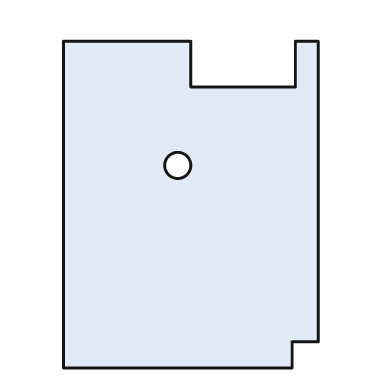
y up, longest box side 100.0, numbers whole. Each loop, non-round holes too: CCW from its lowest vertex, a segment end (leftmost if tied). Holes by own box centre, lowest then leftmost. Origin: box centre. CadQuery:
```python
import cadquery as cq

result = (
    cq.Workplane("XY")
    .moveTo(-39.0, -50.0)
    .lineTo(31.0, -50.0)
    .lineTo(31.0, -42.0)
    .lineTo(39.0, -42.0)
    .lineTo(39.0, 50.0)
    .lineTo(32.0, 50.0)
    .lineTo(32.0, 36.0)
    .lineTo(0.0, 36.0)
    .lineTo(0.0, 50.0)
    .lineTo(-39.0, 50.0)
    .close()
    .moveTo(-4.0, 12.0)
    .circle(4.0)
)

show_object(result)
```